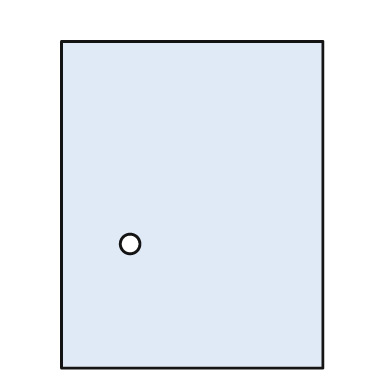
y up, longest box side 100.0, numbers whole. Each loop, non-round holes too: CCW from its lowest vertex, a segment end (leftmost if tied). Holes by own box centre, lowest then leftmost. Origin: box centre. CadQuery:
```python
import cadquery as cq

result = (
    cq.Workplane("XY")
    .moveTo(-40.0, -50.0)
    .lineTo(40.0, -50.0)
    .lineTo(40.0, 50.0)
    .lineTo(-40.0, 50.0)
    .close()
    .moveTo(-19.0, -12.0)
    .circle(3.0)
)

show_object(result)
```